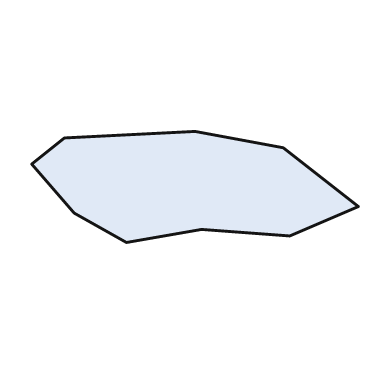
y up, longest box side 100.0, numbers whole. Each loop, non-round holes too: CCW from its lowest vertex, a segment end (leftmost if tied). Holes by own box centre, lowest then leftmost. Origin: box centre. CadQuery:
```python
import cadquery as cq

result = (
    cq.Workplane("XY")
    .moveTo(-21.0, -17.0)
    .lineTo(2.0, -13.0)
    .lineTo(29.0, -15.0)
    .lineTo(50.0, -6.0)
    .lineTo(27.0, 12.0)
    .lineTo(0.0, 17.0)
    .lineTo(-40.0, 15.0)
    .lineTo(-50.0, 7.0)
    .lineTo(-37.0, -8.0)
    .close()
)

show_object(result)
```